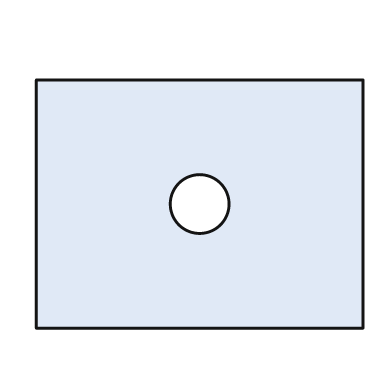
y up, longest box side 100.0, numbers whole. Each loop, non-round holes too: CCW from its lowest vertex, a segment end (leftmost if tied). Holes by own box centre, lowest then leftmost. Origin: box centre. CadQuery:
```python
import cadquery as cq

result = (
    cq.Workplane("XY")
    .moveTo(-50.0, -38.0)
    .lineTo(50.0, -38.0)
    .lineTo(50.0, 38.0)
    .lineTo(-50.0, 38.0)
    .close()
    .moveTo(0.0, 0.0)
    .circle(9.0)
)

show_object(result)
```